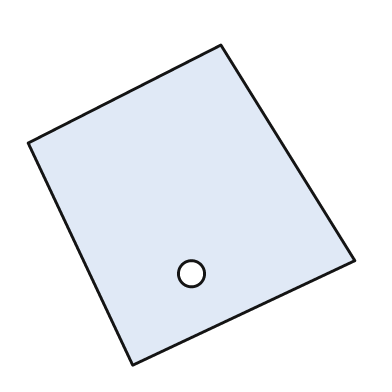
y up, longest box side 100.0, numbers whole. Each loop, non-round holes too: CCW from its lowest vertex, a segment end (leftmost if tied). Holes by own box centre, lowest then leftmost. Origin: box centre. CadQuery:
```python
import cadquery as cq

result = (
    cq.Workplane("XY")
    .moveTo(-18.0, -49.0)
    .lineTo(50.0, -17.0)
    .lineTo(9.0, 49.0)
    .lineTo(-50.0, 19.0)
    .close()
    .moveTo(0.0, -21.0)
    .circle(4.0)
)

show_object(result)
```